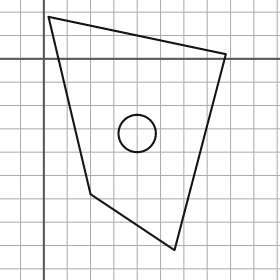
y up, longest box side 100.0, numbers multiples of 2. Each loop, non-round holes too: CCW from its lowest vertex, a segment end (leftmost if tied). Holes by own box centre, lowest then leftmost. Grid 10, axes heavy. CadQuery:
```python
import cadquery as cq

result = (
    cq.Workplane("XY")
    .moveTo(56.0, -82.0)
    .lineTo(78.0, 2.0)
    .lineTo(2.0, 18.0)
    .lineTo(20.0, -58.0)
    .close()
    .moveTo(40.0, -32.0)
    .circle(8.0)
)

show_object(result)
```